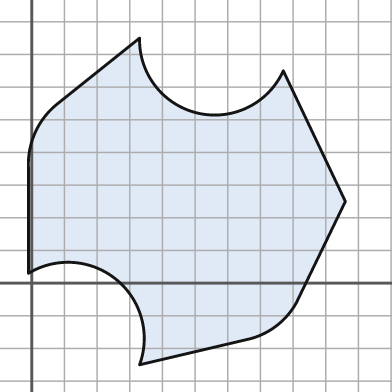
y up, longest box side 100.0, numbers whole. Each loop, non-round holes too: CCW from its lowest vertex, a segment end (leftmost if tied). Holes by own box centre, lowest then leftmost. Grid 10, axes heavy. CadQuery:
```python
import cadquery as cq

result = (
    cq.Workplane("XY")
    .moveTo(33.0, -25.0)
    .lineTo(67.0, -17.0)
    .threePointArc((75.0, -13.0), (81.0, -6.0))
    .lineTo(96.0, 25.0)
    .lineTo(77.0, 65.0)
    .threePointArc((51.0, 52.0), (33.0, 75.0))
    .lineTo(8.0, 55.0)
    .threePointArc((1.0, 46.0), (-1.0, 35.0))
    .lineTo(-1.0, 3.0)
    .threePointArc((26.0, 1.0), (33.0, -25.0))
    .close()
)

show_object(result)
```